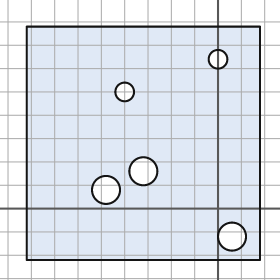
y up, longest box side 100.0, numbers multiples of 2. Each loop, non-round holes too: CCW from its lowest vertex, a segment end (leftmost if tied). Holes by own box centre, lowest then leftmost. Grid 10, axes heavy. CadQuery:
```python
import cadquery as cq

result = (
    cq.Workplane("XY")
    .moveTo(-82.0, -22.0)
    .lineTo(18.0, -22.0)
    .lineTo(18.0, 78.0)
    .lineTo(-82.0, 78.0)
    .close()
    .moveTo(6.0, -12.0)
    .circle(6.0)
    .moveTo(-48.0, 8.0)
    .circle(6.0)
    .moveTo(-32.0, 16.0)
    .circle(6.0)
    .moveTo(-40.0, 50.0)
    .circle(4.0)
    .moveTo(0.0, 64.0)
    .circle(4.0)
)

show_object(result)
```